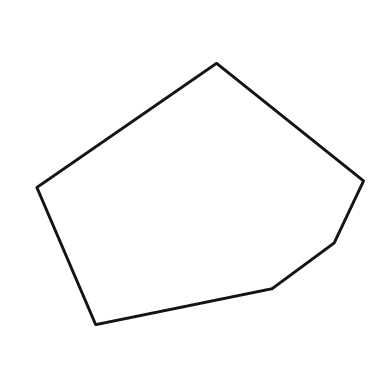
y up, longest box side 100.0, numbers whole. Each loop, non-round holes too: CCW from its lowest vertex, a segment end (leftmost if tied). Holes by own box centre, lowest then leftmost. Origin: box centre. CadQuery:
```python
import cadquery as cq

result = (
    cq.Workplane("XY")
    .moveTo(-32.0, -40.0)
    .lineTo(22.0, -29.0)
    .lineTo(41.0, -15.0)
    .lineTo(50.0, 4.0)
    .lineTo(5.0, 40.0)
    .lineTo(-50.0, 2.0)
    .close()
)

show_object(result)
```